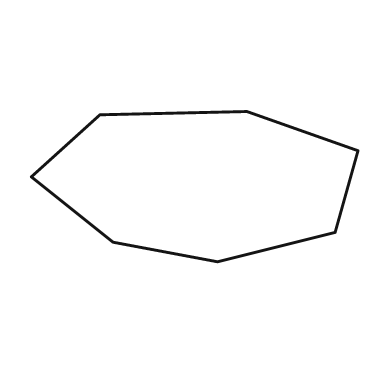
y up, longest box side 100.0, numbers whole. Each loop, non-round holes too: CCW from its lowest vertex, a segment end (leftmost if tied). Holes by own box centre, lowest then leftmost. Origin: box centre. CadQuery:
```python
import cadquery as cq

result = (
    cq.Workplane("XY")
    .moveTo(7.0, -23.0)
    .lineTo(43.0, -14.0)
    .lineTo(50.0, 11.0)
    .lineTo(16.0, 23.0)
    .lineTo(-29.0, 22.0)
    .lineTo(-50.0, 3.0)
    .lineTo(-25.0, -17.0)
    .close()
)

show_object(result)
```